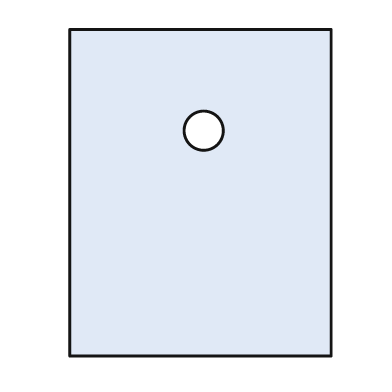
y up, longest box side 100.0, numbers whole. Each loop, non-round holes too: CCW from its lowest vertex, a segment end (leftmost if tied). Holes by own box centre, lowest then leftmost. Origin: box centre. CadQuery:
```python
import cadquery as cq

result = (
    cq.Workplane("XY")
    .moveTo(-40.0, -50.0)
    .lineTo(40.0, -50.0)
    .lineTo(40.0, 50.0)
    .lineTo(-40.0, 50.0)
    .close()
    .moveTo(1.0, 19.0)
    .circle(6.0)
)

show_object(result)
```